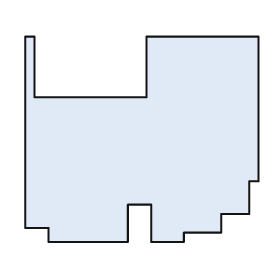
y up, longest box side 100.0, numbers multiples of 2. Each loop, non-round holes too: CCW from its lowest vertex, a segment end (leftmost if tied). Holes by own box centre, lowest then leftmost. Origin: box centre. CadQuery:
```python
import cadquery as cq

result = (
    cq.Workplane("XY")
    .moveTo(-40.0, -44.0)
    .lineTo(-6.0, -44.0)
    .lineTo(-6.0, -28.0)
    .lineTo(4.0, -28.0)
    .lineTo(4.0, -44.0)
    .lineTo(18.0, -44.0)
    .lineTo(18.0, -40.0)
    .lineTo(34.0, -40.0)
    .lineTo(34.0, -32.0)
    .lineTo(46.0, -32.0)
    .lineTo(46.0, -18.0)
    .lineTo(50.0, -18.0)
    .lineTo(50.0, 44.0)
    .lineTo(2.0, 44.0)
    .lineTo(2.0, 18.0)
    .lineTo(-46.0, 18.0)
    .lineTo(-46.0, 44.0)
    .lineTo(-50.0, 44.0)
    .lineTo(-50.0, -38.0)
    .lineTo(-40.0, -38.0)
    .close()
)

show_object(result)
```